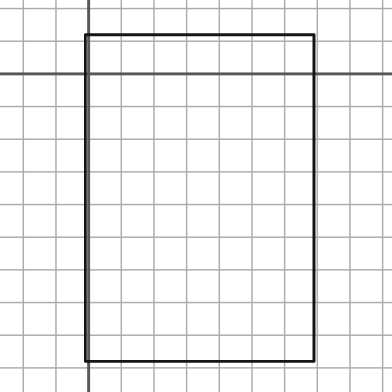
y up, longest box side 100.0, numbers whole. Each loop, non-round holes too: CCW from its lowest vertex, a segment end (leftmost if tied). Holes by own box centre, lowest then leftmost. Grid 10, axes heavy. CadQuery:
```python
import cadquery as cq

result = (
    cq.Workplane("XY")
    .moveTo(-1.0, -88.0)
    .lineTo(69.0, -88.0)
    .lineTo(69.0, 12.0)
    .lineTo(-1.0, 12.0)
    .close()
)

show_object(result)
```